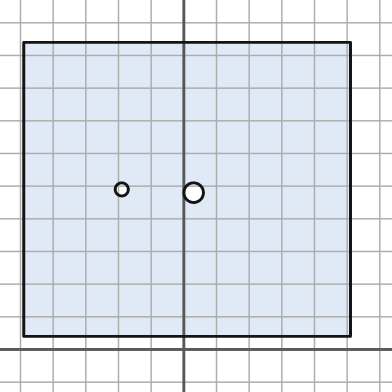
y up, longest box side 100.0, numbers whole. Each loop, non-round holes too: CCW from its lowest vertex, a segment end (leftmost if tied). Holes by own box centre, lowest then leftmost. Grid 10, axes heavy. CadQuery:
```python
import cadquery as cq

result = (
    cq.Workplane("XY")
    .moveTo(-49.0, 4.0)
    .lineTo(51.0, 4.0)
    .lineTo(51.0, 94.0)
    .lineTo(-49.0, 94.0)
    .close()
    .moveTo(3.0, 48.0)
    .circle(3.0)
    .moveTo(-19.0, 49.0)
    .circle(2.0)
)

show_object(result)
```